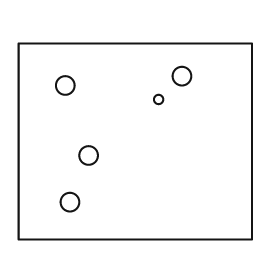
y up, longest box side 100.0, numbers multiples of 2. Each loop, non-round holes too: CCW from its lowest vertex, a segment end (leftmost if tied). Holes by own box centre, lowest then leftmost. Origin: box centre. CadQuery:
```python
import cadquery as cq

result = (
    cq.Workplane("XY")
    .moveTo(-50.0, -42.0)
    .lineTo(50.0, -42.0)
    .lineTo(50.0, 42.0)
    .lineTo(-50.0, 42.0)
    .close()
    .moveTo(-28.0, -26.0)
    .circle(4.0)
    .moveTo(-20.0, -6.0)
    .circle(4.0)
    .moveTo(10.0, 18.0)
    .circle(2.0)
    .moveTo(-30.0, 24.0)
    .circle(4.0)
    .moveTo(20.0, 28.0)
    .circle(4.0)
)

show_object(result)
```